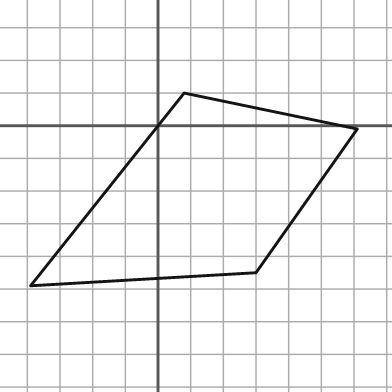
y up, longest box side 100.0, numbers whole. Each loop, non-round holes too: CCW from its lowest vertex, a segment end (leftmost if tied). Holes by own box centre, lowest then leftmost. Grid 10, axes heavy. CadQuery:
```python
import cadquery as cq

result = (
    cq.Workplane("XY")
    .moveTo(-39.0, -49.0)
    .lineTo(30.0, -45.0)
    .lineTo(61.0, -1.0)
    .lineTo(8.0, 10.0)
    .close()
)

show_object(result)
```